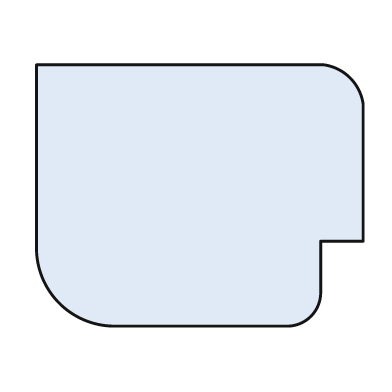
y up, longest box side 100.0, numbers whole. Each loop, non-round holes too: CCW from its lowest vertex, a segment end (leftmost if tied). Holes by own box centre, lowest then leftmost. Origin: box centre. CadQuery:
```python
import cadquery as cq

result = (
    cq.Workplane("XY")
    .moveTo(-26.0, -40.0)
    .lineTo(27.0, -40.0)
    .threePointArc((34.0, -37.0), (37.0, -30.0))
    .lineTo(37.0, -14.0)
    .lineTo(50.0, -14.0)
    .lineTo(50.0, 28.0)
    .threePointArc((46.0, 36.0), (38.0, 40.0))
    .lineTo(-50.0, 40.0)
    .lineTo(-50.0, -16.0)
    .threePointArc((-43.0, -33.0), (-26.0, -40.0))
    .close()
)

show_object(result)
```